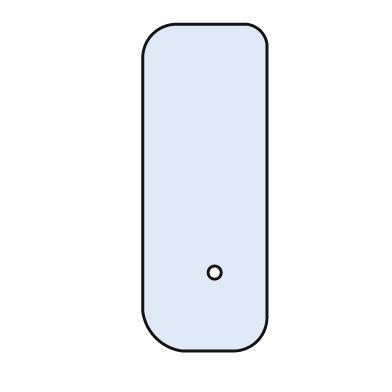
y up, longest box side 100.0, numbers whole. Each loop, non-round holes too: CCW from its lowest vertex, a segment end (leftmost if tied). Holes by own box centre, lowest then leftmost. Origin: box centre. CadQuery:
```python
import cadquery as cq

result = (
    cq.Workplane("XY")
    .moveTo(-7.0, -50.0)
    .lineTo(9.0, -50.0)
    .threePointArc((16.0, -47.0), (19.0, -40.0))
    .lineTo(19.0, 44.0)
    .threePointArc((17.0, 48.0), (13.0, 50.0))
    .lineTo(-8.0, 50.0)
    .threePointArc((-16.0, 47.0), (-19.0, 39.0))
    .lineTo(-19.0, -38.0)
    .threePointArc((-15.0, -46.0), (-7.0, -50.0))
    .close()
    .moveTo(3.0, -26.0)
    .circle(2.0)
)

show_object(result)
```